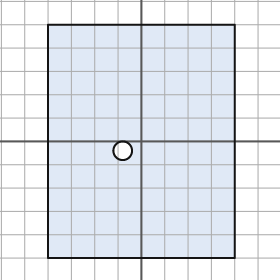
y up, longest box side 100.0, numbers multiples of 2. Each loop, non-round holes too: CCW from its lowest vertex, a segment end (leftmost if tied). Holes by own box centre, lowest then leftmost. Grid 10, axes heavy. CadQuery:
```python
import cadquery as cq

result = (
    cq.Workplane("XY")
    .moveTo(-40.0, -50.0)
    .lineTo(40.0, -50.0)
    .lineTo(40.0, 50.0)
    .lineTo(-40.0, 50.0)
    .close()
    .moveTo(-8.0, -4.0)
    .circle(4.0)
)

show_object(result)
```